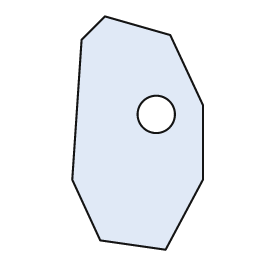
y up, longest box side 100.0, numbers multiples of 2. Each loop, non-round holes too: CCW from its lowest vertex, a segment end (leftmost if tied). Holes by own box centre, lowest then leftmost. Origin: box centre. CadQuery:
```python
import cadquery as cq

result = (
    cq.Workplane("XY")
    .moveTo(12.0, -50.0)
    .lineTo(28.0, -20.0)
    .lineTo(28.0, 12.0)
    .lineTo(14.0, 42.0)
    .lineTo(-14.0, 50.0)
    .lineTo(-24.0, 40.0)
    .lineTo(-28.0, -20.0)
    .lineTo(-16.0, -46.0)
    .close()
    .moveTo(8.0, 8.0)
    .circle(8.0)
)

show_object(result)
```